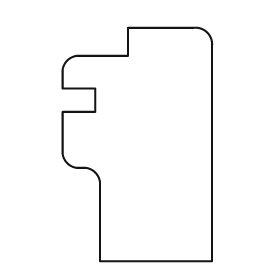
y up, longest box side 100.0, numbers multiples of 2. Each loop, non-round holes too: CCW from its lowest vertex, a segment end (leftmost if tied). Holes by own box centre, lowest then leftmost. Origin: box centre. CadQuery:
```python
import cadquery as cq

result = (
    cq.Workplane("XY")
    .moveTo(-16.0, -50.0)
    .lineTo(32.0, -50.0)
    .lineTo(32.0, 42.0)
    .threePointArc((30.0, 48.0), (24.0, 50.0))
    .lineTo(-4.0, 50.0)
    .lineTo(-4.0, 38.0)
    .lineTo(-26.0, 38.0)
    .threePointArc((-30.0, 36.0), (-32.0, 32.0))
    .lineTo(-32.0, 24.0)
    .lineTo(-18.0, 24.0)
    .lineTo(-18.0, 14.0)
    .lineTo(-32.0, 14.0)
    .lineTo(-32.0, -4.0)
    .threePointArc((-30.0, -8.0), (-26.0, -10.0))
    .lineTo(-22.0, -10.0)
    .threePointArc((-18.0, -12.0), (-16.0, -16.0))
    .close()
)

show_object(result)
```